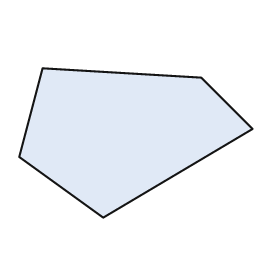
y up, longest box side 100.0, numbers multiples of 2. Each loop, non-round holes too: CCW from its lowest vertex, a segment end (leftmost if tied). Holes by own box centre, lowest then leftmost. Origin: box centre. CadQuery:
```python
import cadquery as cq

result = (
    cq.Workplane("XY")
    .moveTo(-14.0, -32.0)
    .lineTo(50.0, 6.0)
    .lineTo(28.0, 28.0)
    .lineTo(-40.0, 32.0)
    .lineTo(-50.0, -6.0)
    .close()
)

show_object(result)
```